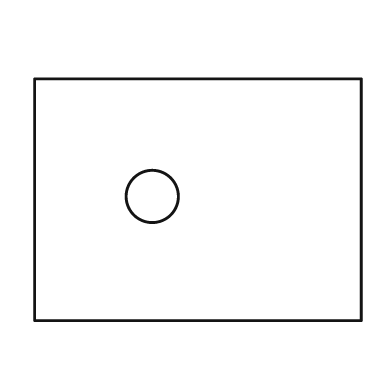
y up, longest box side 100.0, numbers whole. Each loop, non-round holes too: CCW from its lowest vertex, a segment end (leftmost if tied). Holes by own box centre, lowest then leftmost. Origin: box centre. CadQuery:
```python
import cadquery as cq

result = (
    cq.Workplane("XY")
    .moveTo(-50.0, -37.0)
    .lineTo(50.0, -37.0)
    .lineTo(50.0, 37.0)
    .lineTo(-50.0, 37.0)
    .close()
    .moveTo(-14.0, 1.0)
    .circle(8.0)
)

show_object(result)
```